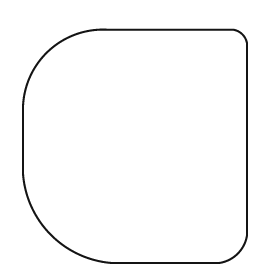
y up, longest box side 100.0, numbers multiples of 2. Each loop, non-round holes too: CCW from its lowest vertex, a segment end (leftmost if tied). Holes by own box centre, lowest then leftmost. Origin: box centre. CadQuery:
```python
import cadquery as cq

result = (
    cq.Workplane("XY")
    .moveTo(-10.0, -50.0)
    .lineTo(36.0, -50.0)
    .threePointArc((44.0, -46.0), (48.0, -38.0))
    .lineTo(48.0, 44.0)
    .threePointArc((46.0, 48.0), (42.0, 50.0))
    .lineTo(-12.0, 50.0)
    .threePointArc((-38.0, 40.0), (-48.0, 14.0))
    .lineTo(-48.0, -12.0)
    .threePointArc((-36.0, -38.0), (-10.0, -50.0))
    .close()
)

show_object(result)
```